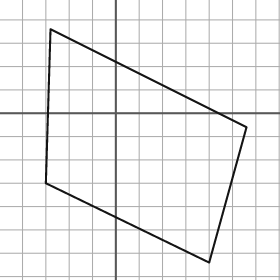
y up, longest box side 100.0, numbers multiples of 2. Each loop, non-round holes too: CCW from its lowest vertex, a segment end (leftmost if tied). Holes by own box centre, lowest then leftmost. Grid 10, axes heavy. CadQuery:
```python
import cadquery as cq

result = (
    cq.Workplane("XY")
    .moveTo(40.0, -64.0)
    .lineTo(56.0, -6.0)
    .lineTo(-28.0, 36.0)
    .lineTo(-30.0, -30.0)
    .close()
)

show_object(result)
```